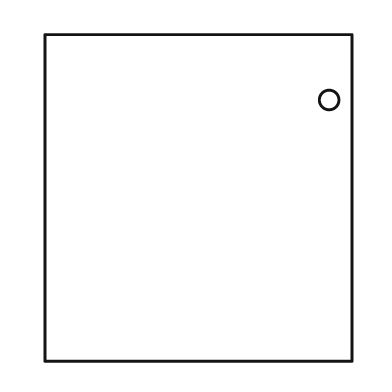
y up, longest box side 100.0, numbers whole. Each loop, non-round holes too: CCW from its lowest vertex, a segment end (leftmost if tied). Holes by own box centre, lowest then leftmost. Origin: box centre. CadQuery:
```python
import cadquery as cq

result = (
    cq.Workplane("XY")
    .moveTo(-47.0, -50.0)
    .lineTo(47.0, -50.0)
    .lineTo(47.0, 50.0)
    .lineTo(-47.0, 50.0)
    .close()
    .moveTo(40.0, 30.0)
    .circle(3.0)
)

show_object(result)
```